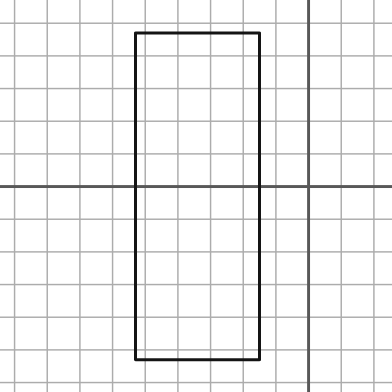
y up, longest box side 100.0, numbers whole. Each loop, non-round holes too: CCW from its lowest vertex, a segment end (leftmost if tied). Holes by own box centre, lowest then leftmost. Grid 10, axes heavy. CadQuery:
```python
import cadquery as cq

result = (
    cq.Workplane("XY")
    .moveTo(-53.0, -53.0)
    .lineTo(-15.0, -53.0)
    .lineTo(-15.0, 47.0)
    .lineTo(-53.0, 47.0)
    .close()
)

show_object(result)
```